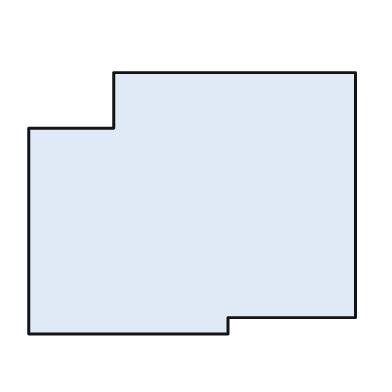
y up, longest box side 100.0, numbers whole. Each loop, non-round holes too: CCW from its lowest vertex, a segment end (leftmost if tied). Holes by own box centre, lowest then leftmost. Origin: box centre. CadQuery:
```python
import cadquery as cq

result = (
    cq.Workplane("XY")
    .moveTo(-50.0, -40.0)
    .lineTo(11.0, -40.0)
    .lineTo(11.0, -35.0)
    .lineTo(50.0, -35.0)
    .lineTo(50.0, 40.0)
    .lineTo(-24.0, 40.0)
    .lineTo(-24.0, 23.0)
    .lineTo(-50.0, 23.0)
    .close()
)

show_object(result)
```